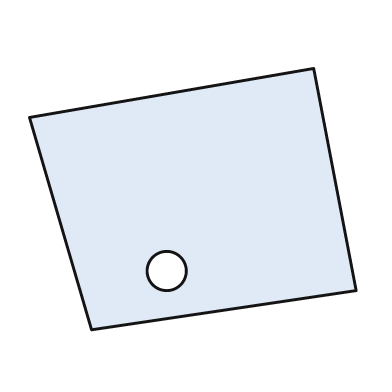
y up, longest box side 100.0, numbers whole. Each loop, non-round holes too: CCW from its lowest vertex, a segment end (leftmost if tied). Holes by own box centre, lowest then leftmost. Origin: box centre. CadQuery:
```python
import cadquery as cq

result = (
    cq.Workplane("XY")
    .moveTo(-31.0, -40.0)
    .lineTo(50.0, -28.0)
    .lineTo(37.0, 40.0)
    .lineTo(-50.0, 25.0)
    .close()
    .moveTo(-8.0, -22.0)
    .circle(6.0)
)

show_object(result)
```